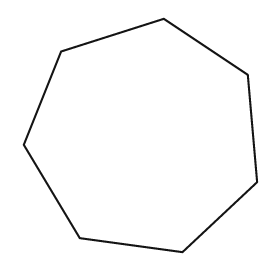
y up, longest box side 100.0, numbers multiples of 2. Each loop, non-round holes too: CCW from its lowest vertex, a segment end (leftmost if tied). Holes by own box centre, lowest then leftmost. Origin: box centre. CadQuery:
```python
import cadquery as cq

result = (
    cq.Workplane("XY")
    .moveTo(18.0, -50.0)
    .lineTo(50.0, -20.0)
    .lineTo(46.0, 26.0)
    .lineTo(10.0, 50.0)
    .lineTo(-34.0, 36.0)
    .lineTo(-50.0, -4.0)
    .lineTo(-26.0, -44.0)
    .close()
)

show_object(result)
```